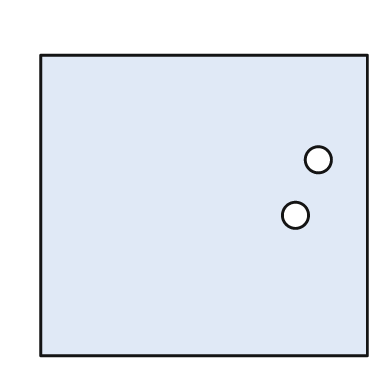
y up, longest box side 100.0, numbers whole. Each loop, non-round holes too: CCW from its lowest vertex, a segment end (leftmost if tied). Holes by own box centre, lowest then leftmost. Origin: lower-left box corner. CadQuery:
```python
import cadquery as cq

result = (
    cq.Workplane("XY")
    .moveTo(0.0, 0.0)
    .lineTo(100.0, 0.0)
    .lineTo(100.0, 92.0)
    .lineTo(0.0, 92.0)
    .close()
    .moveTo(78.0, 43.0)
    .circle(4.0)
    .moveTo(85.0, 60.0)
    .circle(4.0)
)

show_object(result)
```